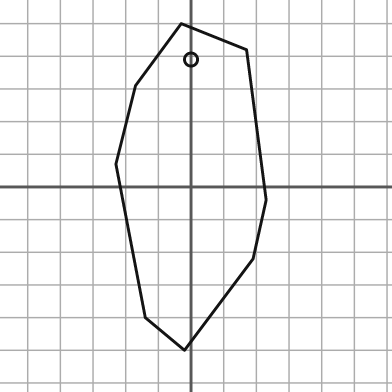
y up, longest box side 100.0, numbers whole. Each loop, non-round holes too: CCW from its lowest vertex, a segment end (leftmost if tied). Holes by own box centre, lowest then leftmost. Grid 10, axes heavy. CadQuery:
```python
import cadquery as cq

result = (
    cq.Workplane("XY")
    .moveTo(-2.0, -50.0)
    .lineTo(19.0, -22.0)
    .lineTo(23.0, -4.0)
    .lineTo(17.0, 42.0)
    .lineTo(-3.0, 50.0)
    .lineTo(-17.0, 31.0)
    .lineTo(-23.0, 7.0)
    .lineTo(-14.0, -40.0)
    .close()
    .moveTo(0.0, 39.0)
    .circle(2.0)
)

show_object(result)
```